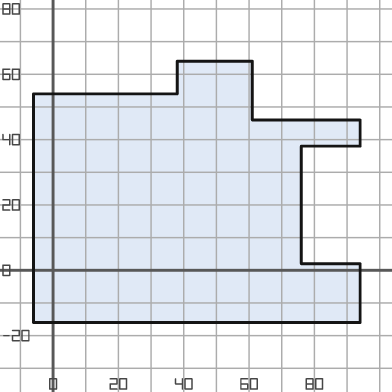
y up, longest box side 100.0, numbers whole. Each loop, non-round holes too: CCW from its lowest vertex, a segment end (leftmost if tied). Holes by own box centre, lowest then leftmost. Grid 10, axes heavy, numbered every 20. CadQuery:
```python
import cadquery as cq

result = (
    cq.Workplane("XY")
    .moveTo(-6.0, -16.0)
    .lineTo(94.0, -16.0)
    .lineTo(94.0, 2.0)
    .lineTo(76.0, 2.0)
    .lineTo(76.0, 38.0)
    .lineTo(94.0, 38.0)
    .lineTo(94.0, 46.0)
    .lineTo(61.0, 46.0)
    .lineTo(61.0, 64.0)
    .lineTo(38.0, 64.0)
    .lineTo(38.0, 54.0)
    .lineTo(-6.0, 54.0)
    .close()
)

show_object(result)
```